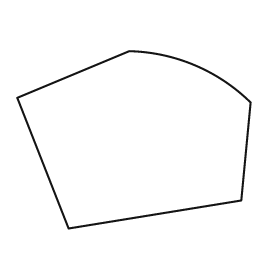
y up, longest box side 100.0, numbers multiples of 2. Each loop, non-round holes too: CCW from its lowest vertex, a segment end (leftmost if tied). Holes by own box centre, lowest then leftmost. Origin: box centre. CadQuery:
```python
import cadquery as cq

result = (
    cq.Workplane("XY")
    .moveTo(-28.0, -38.0)
    .lineTo(46.0, -26.0)
    .lineTo(50.0, 16.0)
    .threePointArc((26.0, 32.0), (-2.0, 38.0))
    .lineTo(-50.0, 18.0)
    .close()
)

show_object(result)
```